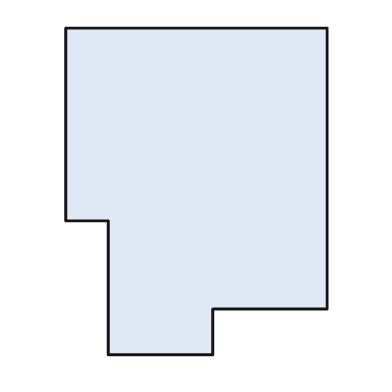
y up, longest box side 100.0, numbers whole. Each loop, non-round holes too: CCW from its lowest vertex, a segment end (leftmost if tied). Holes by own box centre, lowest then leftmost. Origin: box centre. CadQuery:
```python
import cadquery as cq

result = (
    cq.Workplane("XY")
    .moveTo(-27.0, -50.0)
    .lineTo(5.0, -50.0)
    .lineTo(5.0, -36.0)
    .lineTo(40.0, -36.0)
    .lineTo(40.0, 50.0)
    .lineTo(-40.0, 50.0)
    .lineTo(-40.0, -9.0)
    .lineTo(-27.0, -9.0)
    .close()
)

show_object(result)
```